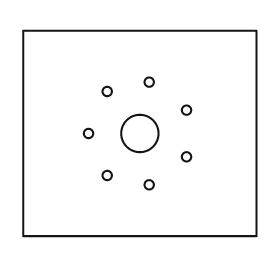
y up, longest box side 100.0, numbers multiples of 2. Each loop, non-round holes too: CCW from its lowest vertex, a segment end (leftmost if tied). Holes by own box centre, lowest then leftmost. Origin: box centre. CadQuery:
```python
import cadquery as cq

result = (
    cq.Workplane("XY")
    .moveTo(-50.0, -44.0)
    .lineTo(50.0, -44.0)
    .lineTo(50.0, 44.0)
    .lineTo(-50.0, 44.0)
    .close()
    .moveTo(4.0, -22.0)
    .circle(2.0)
    .moveTo(-14.0, -18.0)
    .circle(2.0)
    .moveTo(20.0, -10.0)
    .circle(2.0)
    .moveTo(-22.0, 0.0)
    .circle(2.0)
    .moveTo(0.0, 0.0)
    .circle(8.0)
    .moveTo(20.0, 10.0)
    .circle(2.0)
    .moveTo(-14.0, 18.0)
    .circle(2.0)
    .moveTo(4.0, 22.0)
    .circle(2.0)
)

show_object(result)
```